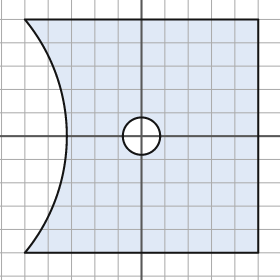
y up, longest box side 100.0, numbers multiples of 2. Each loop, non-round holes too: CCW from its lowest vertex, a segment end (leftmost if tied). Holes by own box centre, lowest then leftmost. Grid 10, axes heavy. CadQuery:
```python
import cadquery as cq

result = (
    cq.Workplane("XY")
    .moveTo(-50.0, -50.0)
    .lineTo(50.0, -50.0)
    .lineTo(50.0, 50.0)
    .lineTo(-50.0, 50.0)
    .threePointArc((-32.0, 0.0), (-50.0, -50.0))
    .close()
    .moveTo(0.0, 0.0)
    .circle(8.0)
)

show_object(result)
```